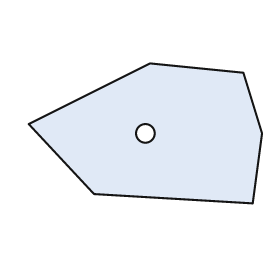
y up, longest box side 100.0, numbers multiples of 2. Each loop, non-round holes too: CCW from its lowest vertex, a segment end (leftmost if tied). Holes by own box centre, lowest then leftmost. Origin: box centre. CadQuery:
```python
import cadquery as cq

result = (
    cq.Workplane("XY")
    .moveTo(46.0, -30.0)
    .lineTo(50.0, 0.0)
    .lineTo(42.0, 26.0)
    .lineTo(2.0, 30.0)
    .lineTo(-50.0, 4.0)
    .lineTo(-22.0, -26.0)
    .close()
    .moveTo(0.0, 0.0)
    .circle(4.0)
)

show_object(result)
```